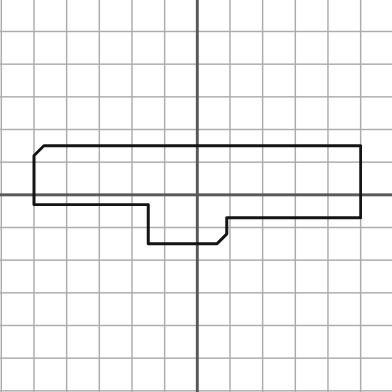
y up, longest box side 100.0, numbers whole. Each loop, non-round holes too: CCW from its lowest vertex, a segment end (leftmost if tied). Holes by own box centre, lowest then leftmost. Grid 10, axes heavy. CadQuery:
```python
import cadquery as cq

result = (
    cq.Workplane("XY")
    .moveTo(-15.0, -15.0)
    .lineTo(6.0, -15.0)
    .lineTo(9.0, -12.0)
    .lineTo(9.0, -7.0)
    .lineTo(50.0, -7.0)
    .lineTo(50.0, 15.0)
    .lineTo(-47.0, 15.0)
    .lineTo(-50.0, 12.0)
    .lineTo(-50.0, -3.0)
    .lineTo(-15.0, -3.0)
    .close()
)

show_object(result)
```